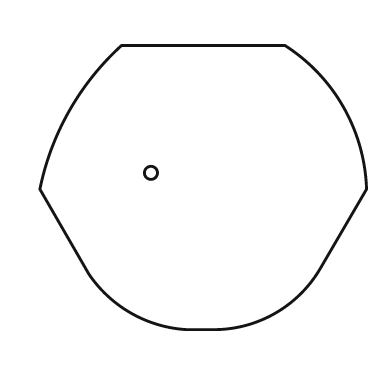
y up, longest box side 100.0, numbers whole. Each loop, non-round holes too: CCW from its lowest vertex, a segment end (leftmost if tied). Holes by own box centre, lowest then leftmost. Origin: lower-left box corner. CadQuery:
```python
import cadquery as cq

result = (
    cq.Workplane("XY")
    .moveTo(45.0, 0.0)
    .lineTo(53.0, 0.0)
    .threePointArc((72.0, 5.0), (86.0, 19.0))
    .lineTo(100.0, 43.0)
    .threePointArc((93.0, 68.0), (75.0, 87.0))
    .lineTo(25.0, 87.0)
    .threePointArc((9.0, 67.0), (0.0, 43.0))
    .lineTo(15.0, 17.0)
    .threePointArc((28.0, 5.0), (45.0, 0.0))
    .close()
    .moveTo(34.0, 48.0)
    .circle(2.0)
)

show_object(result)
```